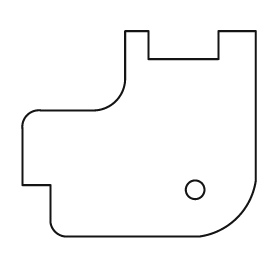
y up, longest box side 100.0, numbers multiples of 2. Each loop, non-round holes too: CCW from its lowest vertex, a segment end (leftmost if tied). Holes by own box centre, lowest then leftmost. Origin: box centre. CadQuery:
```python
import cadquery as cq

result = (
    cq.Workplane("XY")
    .moveTo(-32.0, -44.0)
    .lineTo(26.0, -44.0)
    .threePointArc((42.0, -36.0), (50.0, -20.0))
    .lineTo(50.0, 44.0)
    .lineTo(34.0, 44.0)
    .lineTo(34.0, 32.0)
    .lineTo(4.0, 32.0)
    .lineTo(4.0, 44.0)
    .lineTo(-6.0, 44.0)
    .lineTo(-6.0, 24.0)
    .threePointArc((-10.0, 14.0), (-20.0, 10.0))
    .lineTo(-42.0, 10.0)
    .threePointArc((-48.0, 8.0), (-50.0, 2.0))
    .lineTo(-50.0, -22.0)
    .lineTo(-38.0, -22.0)
    .lineTo(-38.0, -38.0)
    .threePointArc((-36.0, -42.0), (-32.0, -44.0))
    .close()
    .moveTo(24.0, -24.0)
    .circle(4.0)
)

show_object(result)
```